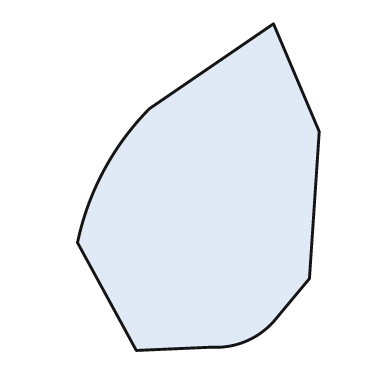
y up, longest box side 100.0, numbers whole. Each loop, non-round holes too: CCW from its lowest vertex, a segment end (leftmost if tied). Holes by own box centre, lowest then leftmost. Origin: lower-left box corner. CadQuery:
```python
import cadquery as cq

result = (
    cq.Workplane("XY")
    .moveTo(18.0, 0.0)
    .lineTo(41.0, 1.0)
    .threePointArc((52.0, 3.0), (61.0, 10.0))
    .lineTo(71.0, 22.0)
    .lineTo(74.0, 67.0)
    .lineTo(60.0, 100.0)
    .lineTo(22.0, 74.0)
    .threePointArc((8.0, 55.0), (0.0, 33.0))
    .close()
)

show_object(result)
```